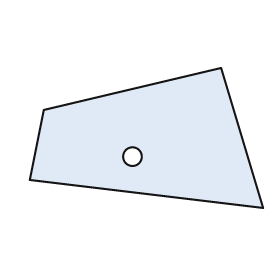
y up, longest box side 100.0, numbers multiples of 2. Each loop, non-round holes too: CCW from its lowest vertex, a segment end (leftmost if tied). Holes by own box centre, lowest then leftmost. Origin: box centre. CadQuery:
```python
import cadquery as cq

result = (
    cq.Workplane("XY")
    .moveTo(50.0, -30.0)
    .lineTo(32.0, 30.0)
    .lineTo(-44.0, 12.0)
    .lineTo(-50.0, -18.0)
    .close()
    .moveTo(-6.0, -8.0)
    .circle(4.0)
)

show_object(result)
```